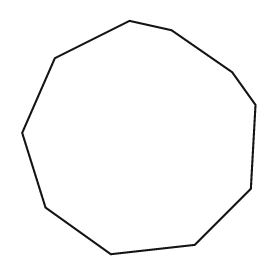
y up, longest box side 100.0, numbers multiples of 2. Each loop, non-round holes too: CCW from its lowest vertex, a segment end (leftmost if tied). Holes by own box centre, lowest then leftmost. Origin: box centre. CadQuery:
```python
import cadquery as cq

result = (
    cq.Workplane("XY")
    .moveTo(-12.0, -50.0)
    .lineTo(24.0, -46.0)
    .lineTo(48.0, -22.0)
    .lineTo(50.0, 14.0)
    .lineTo(40.0, 28.0)
    .lineTo(14.0, 46.0)
    .lineTo(-4.0, 50.0)
    .lineTo(-36.0, 34.0)
    .lineTo(-50.0, 2.0)
    .lineTo(-40.0, -30.0)
    .close()
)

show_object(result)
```